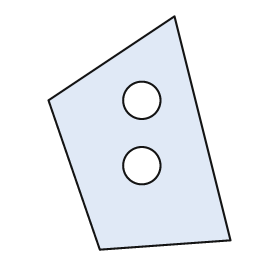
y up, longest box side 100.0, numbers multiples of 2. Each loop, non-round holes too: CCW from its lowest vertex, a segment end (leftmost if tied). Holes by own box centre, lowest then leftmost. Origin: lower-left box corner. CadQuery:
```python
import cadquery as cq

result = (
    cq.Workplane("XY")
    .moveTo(22.0, 0.0)
    .lineTo(78.0, 4.0)
    .lineTo(54.0, 100.0)
    .lineTo(0.0, 64.0)
    .close()
    .moveTo(40.0, 36.0)
    .circle(8.0)
    .moveTo(40.0, 64.0)
    .circle(8.0)
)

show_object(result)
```